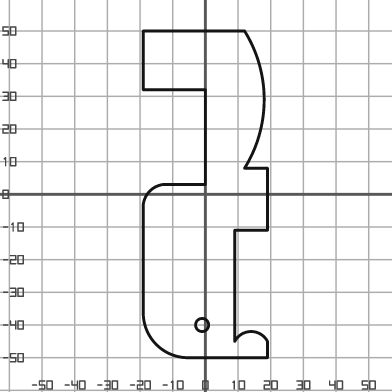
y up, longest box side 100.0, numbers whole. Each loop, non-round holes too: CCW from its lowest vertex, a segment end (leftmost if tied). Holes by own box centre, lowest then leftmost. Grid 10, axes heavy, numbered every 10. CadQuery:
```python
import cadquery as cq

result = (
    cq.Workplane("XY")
    .moveTo(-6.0, -50.0)
    .lineTo(19.0, -50.0)
    .lineTo(19.0, -45.0)
    .threePointArc((14.0, -42.0), (9.0, -45.0))
    .lineTo(9.0, -11.0)
    .lineTo(19.0, -11.0)
    .lineTo(19.0, 8.0)
    .lineTo(12.0, 8.0)
    .threePointArc((18.0, 29.0), (12.0, 50.0))
    .lineTo(-19.0, 50.0)
    .lineTo(-19.0, 32.0)
    .lineTo(0.0, 32.0)
    .lineTo(0.0, 3.0)
    .lineTo(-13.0, 3.0)
    .threePointArc((-17.0, 1.0), (-19.0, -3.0))
    .lineTo(-19.0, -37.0)
    .threePointArc((-15.0, -46.0), (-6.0, -50.0))
    .close()
    .moveTo(-1.0, -40.0)
    .circle(2.0)
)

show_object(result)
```